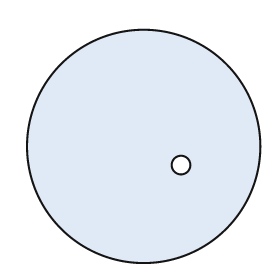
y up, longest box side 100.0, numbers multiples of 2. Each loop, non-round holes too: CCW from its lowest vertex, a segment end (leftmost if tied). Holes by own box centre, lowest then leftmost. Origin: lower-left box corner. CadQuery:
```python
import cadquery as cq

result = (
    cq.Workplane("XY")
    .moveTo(50.0, 50.0)
    .circle(50.0)
    .moveTo(66.0, 42.0)
    .circle(4.0)
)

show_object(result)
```